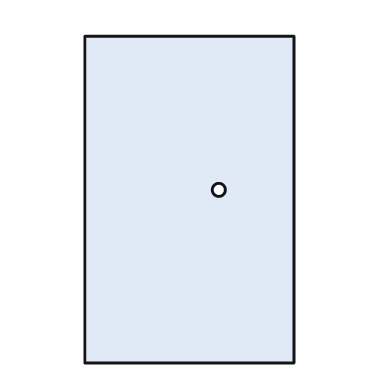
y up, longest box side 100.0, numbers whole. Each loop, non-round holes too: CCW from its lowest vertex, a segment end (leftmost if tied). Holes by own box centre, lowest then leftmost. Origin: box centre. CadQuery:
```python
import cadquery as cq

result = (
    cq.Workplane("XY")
    .moveTo(-32.0, -50.0)
    .lineTo(32.0, -50.0)
    .lineTo(32.0, 50.0)
    .lineTo(-32.0, 50.0)
    .close()
    .moveTo(9.0, 3.0)
    .circle(2.0)
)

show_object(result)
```